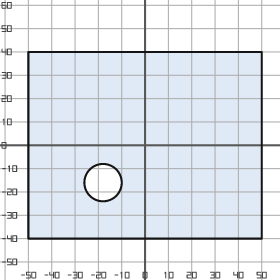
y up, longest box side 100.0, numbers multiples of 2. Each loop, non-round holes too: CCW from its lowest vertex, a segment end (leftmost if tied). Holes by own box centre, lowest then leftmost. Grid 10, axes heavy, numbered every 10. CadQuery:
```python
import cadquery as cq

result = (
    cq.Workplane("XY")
    .moveTo(-50.0, -40.0)
    .lineTo(50.0, -40.0)
    .lineTo(50.0, 40.0)
    .lineTo(-50.0, 40.0)
    .close()
    .moveTo(-18.0, -16.0)
    .circle(8.0)
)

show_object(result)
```